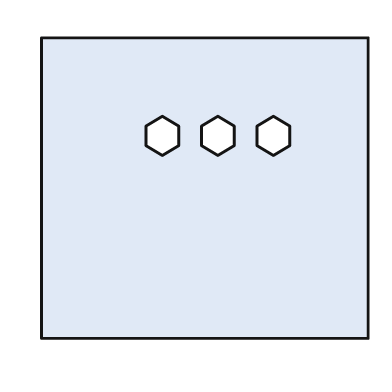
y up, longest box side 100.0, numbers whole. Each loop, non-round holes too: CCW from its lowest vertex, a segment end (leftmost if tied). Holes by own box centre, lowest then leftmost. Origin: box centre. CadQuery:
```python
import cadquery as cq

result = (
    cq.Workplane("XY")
    .moveTo(-50.0, -46.0)
    .lineTo(50.0, -46.0)
    .lineTo(50.0, 46.0)
    .lineTo(-50.0, 46.0)
    .close()
    .moveTo(-13.0, 10.0)
    .lineTo(-8.0, 13.0)
    .lineTo(-8.0, 19.0)
    .lineTo(-13.0, 22.0)
    .lineTo(-18.0, 19.0)
    .lineTo(-18.0, 13.0)
    .close()
    .moveTo(4.0, 10.0)
    .lineTo(9.0, 13.0)
    .lineTo(9.0, 19.0)
    .lineTo(4.0, 22.0)
    .lineTo(-1.0, 19.0)
    .lineTo(-1.0, 13.0)
    .close()
    .moveTo(21.0, 10.0)
    .lineTo(26.0, 13.0)
    .lineTo(26.0, 19.0)
    .lineTo(21.0, 22.0)
    .lineTo(16.0, 19.0)
    .lineTo(16.0, 13.0)
    .close()
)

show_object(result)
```